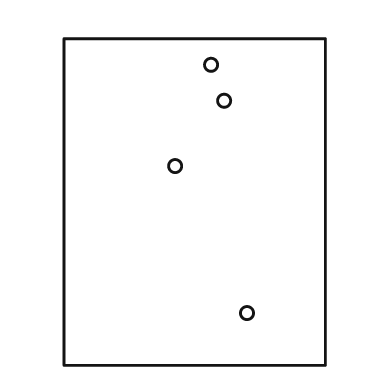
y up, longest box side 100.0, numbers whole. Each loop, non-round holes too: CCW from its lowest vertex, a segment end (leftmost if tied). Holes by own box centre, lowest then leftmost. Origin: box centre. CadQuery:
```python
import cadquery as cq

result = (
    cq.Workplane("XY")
    .moveTo(-40.0, -50.0)
    .lineTo(40.0, -50.0)
    .lineTo(40.0, 50.0)
    .lineTo(-40.0, 50.0)
    .close()
    .moveTo(16.0, -34.0)
    .circle(2.0)
    .moveTo(-6.0, 11.0)
    .circle(2.0)
    .moveTo(9.0, 31.0)
    .circle(2.0)
    .moveTo(5.0, 42.0)
    .circle(2.0)
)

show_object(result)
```